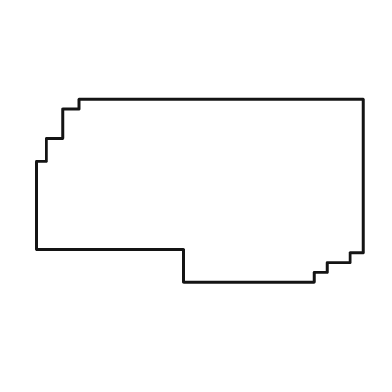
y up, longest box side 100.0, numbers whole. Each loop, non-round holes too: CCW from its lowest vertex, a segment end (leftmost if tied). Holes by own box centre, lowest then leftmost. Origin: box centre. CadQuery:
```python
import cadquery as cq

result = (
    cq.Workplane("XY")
    .moveTo(-5.0, -28.0)
    .lineTo(35.0, -28.0)
    .lineTo(35.0, -25.0)
    .lineTo(39.0, -25.0)
    .lineTo(39.0, -22.0)
    .lineTo(46.0, -22.0)
    .lineTo(46.0, -19.0)
    .lineTo(50.0, -19.0)
    .lineTo(50.0, 28.0)
    .lineTo(-37.0, 28.0)
    .lineTo(-37.0, 25.0)
    .lineTo(-42.0, 25.0)
    .lineTo(-42.0, 16.0)
    .lineTo(-47.0, 16.0)
    .lineTo(-47.0, 9.0)
    .lineTo(-50.0, 9.0)
    .lineTo(-50.0, -18.0)
    .lineTo(-5.0, -18.0)
    .close()
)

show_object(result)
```